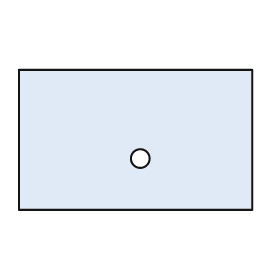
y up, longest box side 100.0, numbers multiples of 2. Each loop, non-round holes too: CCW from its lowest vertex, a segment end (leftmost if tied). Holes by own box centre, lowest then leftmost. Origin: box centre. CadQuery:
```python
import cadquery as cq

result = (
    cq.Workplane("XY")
    .moveTo(-50.0, -30.0)
    .lineTo(50.0, -30.0)
    .lineTo(50.0, 30.0)
    .lineTo(-50.0, 30.0)
    .close()
    .moveTo(2.0, -8.0)
    .circle(4.0)
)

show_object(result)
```